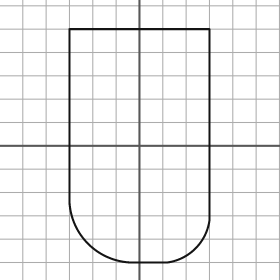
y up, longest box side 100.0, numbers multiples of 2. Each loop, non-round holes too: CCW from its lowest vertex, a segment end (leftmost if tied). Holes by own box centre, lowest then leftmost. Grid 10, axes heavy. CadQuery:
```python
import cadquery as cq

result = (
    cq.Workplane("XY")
    .moveTo(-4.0, -50.0)
    .lineTo(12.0, -50.0)
    .threePointArc((24.0, -44.0), (30.0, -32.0))
    .lineTo(30.0, 50.0)
    .lineTo(-30.0, 50.0)
    .lineTo(-30.0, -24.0)
    .threePointArc((-22.0, -42.0), (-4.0, -50.0))
    .close()
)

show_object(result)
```